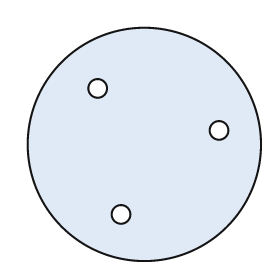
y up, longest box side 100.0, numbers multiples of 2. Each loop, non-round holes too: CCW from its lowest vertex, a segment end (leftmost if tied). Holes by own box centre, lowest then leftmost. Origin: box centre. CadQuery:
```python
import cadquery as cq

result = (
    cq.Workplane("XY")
    .moveTo(0.0, 0.0)
    .circle(50.0)
    .moveTo(-10.0, -30.0)
    .circle(4.0)
    .moveTo(32.0, 6.0)
    .circle(4.0)
    .moveTo(-20.0, 24.0)
    .circle(4.0)
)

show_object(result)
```